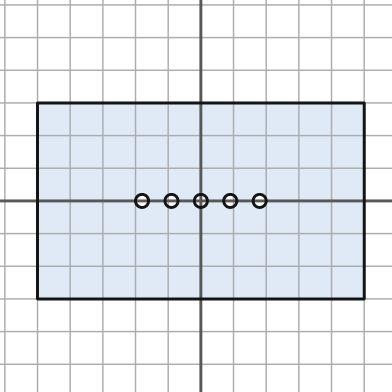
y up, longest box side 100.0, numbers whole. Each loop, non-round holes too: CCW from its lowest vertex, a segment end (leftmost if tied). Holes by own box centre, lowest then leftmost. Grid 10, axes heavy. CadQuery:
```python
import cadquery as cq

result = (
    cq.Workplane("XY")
    .moveTo(-50.0, -30.0)
    .lineTo(50.0, -30.0)
    .lineTo(50.0, 30.0)
    .lineTo(-50.0, 30.0)
    .close()
    .moveTo(-18.0, 0.0)
    .circle(2.0)
    .moveTo(-9.0, 0.0)
    .circle(2.0)
    .moveTo(0.0, 0.0)
    .circle(2.0)
    .moveTo(9.0, 0.0)
    .circle(2.0)
    .moveTo(18.0, 0.0)
    .circle(2.0)
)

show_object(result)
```